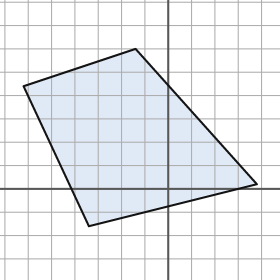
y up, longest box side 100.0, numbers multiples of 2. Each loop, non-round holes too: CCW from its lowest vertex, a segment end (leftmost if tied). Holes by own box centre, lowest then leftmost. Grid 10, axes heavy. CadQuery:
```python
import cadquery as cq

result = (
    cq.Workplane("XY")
    .moveTo(-34.0, -16.0)
    .lineTo(38.0, 2.0)
    .lineTo(-14.0, 60.0)
    .lineTo(-62.0, 44.0)
    .close()
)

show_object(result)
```